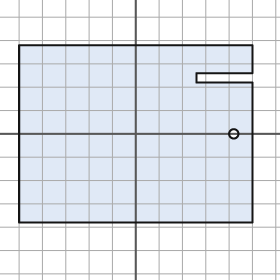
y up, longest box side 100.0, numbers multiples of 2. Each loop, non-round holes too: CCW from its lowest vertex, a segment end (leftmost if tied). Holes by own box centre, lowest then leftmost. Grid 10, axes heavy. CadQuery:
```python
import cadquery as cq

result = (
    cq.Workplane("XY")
    .moveTo(-50.0, -38.0)
    .lineTo(50.0, -38.0)
    .lineTo(50.0, 22.0)
    .lineTo(26.0, 22.0)
    .lineTo(26.0, 26.0)
    .lineTo(50.0, 26.0)
    .lineTo(50.0, 38.0)
    .lineTo(-50.0, 38.0)
    .close()
    .moveTo(42.0, 0.0)
    .circle(2.0)
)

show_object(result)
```